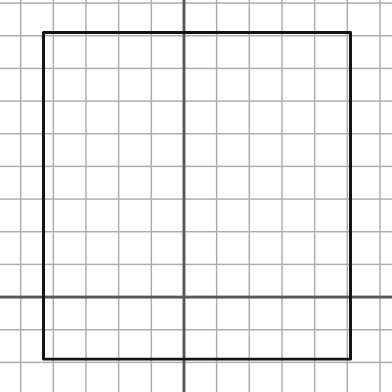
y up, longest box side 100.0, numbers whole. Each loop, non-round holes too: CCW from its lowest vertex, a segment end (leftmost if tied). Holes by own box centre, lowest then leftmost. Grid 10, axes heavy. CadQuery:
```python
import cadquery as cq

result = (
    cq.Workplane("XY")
    .moveTo(-43.0, -19.0)
    .lineTo(51.0, -19.0)
    .lineTo(51.0, 81.0)
    .lineTo(-43.0, 81.0)
    .close()
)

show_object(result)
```